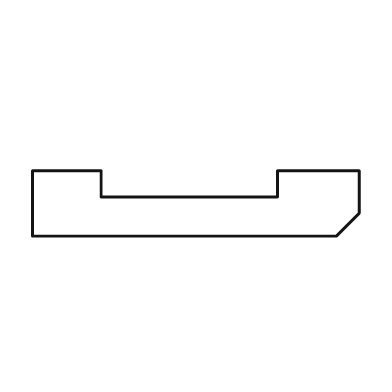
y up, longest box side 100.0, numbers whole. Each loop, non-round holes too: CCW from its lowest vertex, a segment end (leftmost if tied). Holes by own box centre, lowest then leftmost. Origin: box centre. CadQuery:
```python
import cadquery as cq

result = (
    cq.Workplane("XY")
    .moveTo(-50.0, -10.0)
    .lineTo(43.0, -10.0)
    .lineTo(50.0, -3.0)
    .lineTo(50.0, 10.0)
    .lineTo(25.0, 10.0)
    .lineTo(25.0, 2.0)
    .lineTo(-29.0, 2.0)
    .lineTo(-29.0, 10.0)
    .lineTo(-50.0, 10.0)
    .close()
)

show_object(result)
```